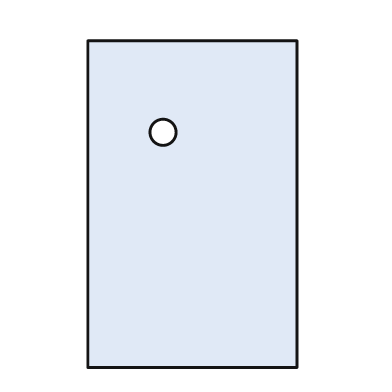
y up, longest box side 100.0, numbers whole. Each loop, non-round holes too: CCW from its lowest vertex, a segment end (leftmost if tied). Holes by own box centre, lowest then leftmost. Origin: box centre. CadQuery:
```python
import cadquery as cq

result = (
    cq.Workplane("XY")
    .moveTo(-32.0, -50.0)
    .lineTo(32.0, -50.0)
    .lineTo(32.0, 50.0)
    .lineTo(-32.0, 50.0)
    .close()
    .moveTo(-9.0, 22.0)
    .circle(4.0)
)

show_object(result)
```